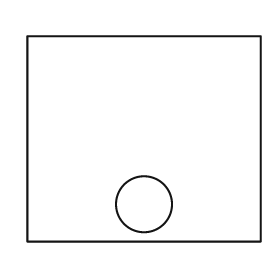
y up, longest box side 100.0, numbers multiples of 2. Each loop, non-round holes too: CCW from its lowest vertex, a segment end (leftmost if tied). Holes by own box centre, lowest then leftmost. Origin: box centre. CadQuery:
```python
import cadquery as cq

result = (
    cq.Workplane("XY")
    .moveTo(-50.0, -44.0)
    .lineTo(50.0, -44.0)
    .lineTo(50.0, 44.0)
    .lineTo(-50.0, 44.0)
    .close()
    .moveTo(0.0, -28.0)
    .circle(12.0)
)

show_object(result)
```